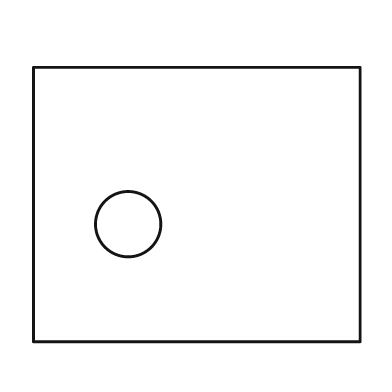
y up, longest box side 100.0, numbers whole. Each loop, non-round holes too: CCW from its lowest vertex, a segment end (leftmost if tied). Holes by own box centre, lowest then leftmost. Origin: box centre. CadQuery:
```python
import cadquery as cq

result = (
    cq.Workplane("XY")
    .moveTo(-50.0, -42.0)
    .lineTo(50.0, -42.0)
    .lineTo(50.0, 42.0)
    .lineTo(-50.0, 42.0)
    .close()
    .moveTo(-21.0, -6.0)
    .circle(10.0)
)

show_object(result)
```